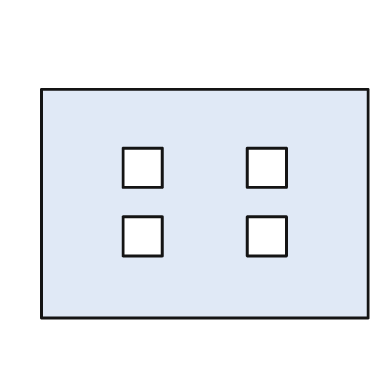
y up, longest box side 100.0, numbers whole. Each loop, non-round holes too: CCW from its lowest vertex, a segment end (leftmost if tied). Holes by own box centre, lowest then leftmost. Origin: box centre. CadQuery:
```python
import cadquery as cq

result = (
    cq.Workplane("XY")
    .moveTo(-50.0, -35.0)
    .lineTo(50.0, -35.0)
    .lineTo(50.0, 35.0)
    .lineTo(-50.0, 35.0)
    .close()
    .moveTo(-25.0, -16.0)
    .lineTo(-13.0, -16.0)
    .lineTo(-13.0, -4.0)
    .lineTo(-25.0, -4.0)
    .close()
    .moveTo(13.0, -16.0)
    .lineTo(25.0, -16.0)
    .lineTo(25.0, -4.0)
    .lineTo(13.0, -4.0)
    .close()
    .moveTo(-25.0, 5.0)
    .lineTo(-13.0, 5.0)
    .lineTo(-13.0, 17.0)
    .lineTo(-25.0, 17.0)
    .close()
    .moveTo(13.0, 5.0)
    .lineTo(25.0, 5.0)
    .lineTo(25.0, 17.0)
    .lineTo(13.0, 17.0)
    .close()
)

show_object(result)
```